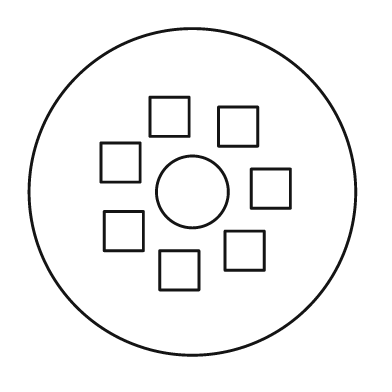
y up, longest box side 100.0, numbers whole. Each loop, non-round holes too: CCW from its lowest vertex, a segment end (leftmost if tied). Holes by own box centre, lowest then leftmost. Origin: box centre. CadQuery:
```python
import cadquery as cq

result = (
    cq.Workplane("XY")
    .moveTo(0.0, 0.0)
    .circle(50.0)
    .moveTo(-10.0, -30.0)
    .lineTo(2.0, -30.0)
    .lineTo(2.0, -18.0)
    .lineTo(-10.0, -18.0)
    .close()
    .moveTo(10.0, -24.0)
    .lineTo(22.0, -24.0)
    .lineTo(22.0, -12.0)
    .lineTo(10.0, -12.0)
    .close()
    .moveTo(-27.0, -18.0)
    .lineTo(-15.0, -18.0)
    .lineTo(-15.0, -6.0)
    .lineTo(-27.0, -6.0)
    .close()
    .moveTo(0.0, 0.0)
    .circle(11.0)
    .moveTo(18.0, -5.0)
    .lineTo(30.0, -5.0)
    .lineTo(30.0, 7.0)
    .lineTo(18.0, 7.0)
    .close()
    .moveTo(-28.0, 3.0)
    .lineTo(-16.0, 3.0)
    .lineTo(-16.0, 15.0)
    .lineTo(-28.0, 15.0)
    .close()
    .moveTo(8.0, 14.0)
    .lineTo(20.0, 14.0)
    .lineTo(20.0, 26.0)
    .lineTo(8.0, 26.0)
    .close()
    .moveTo(-13.0, 17.0)
    .lineTo(-1.0, 17.0)
    .lineTo(-1.0, 29.0)
    .lineTo(-13.0, 29.0)
    .close()
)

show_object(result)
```